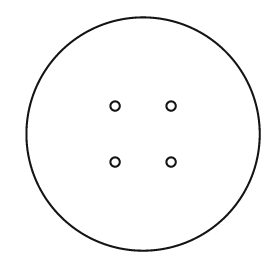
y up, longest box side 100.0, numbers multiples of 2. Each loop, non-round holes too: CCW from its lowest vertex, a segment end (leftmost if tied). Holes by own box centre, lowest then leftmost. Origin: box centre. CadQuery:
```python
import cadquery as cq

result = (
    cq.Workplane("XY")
    .moveTo(0.0, 0.0)
    .circle(50.0)
    .moveTo(-12.0, -12.0)
    .circle(2.0)
    .moveTo(12.0, -12.0)
    .circle(2.0)
    .moveTo(-12.0, 12.0)
    .circle(2.0)
    .moveTo(12.0, 12.0)
    .circle(2.0)
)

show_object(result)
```